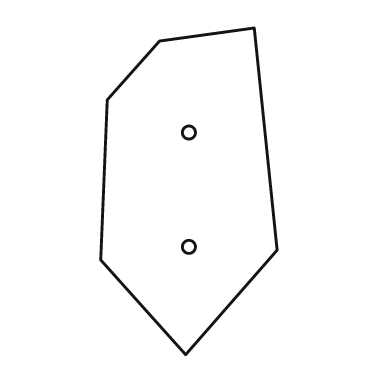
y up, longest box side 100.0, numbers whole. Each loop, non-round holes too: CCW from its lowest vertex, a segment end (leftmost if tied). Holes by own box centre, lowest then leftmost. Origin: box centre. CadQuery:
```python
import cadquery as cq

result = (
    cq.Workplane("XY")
    .moveTo(-1.0, -50.0)
    .lineTo(27.0, -18.0)
    .lineTo(20.0, 50.0)
    .lineTo(-9.0, 46.0)
    .lineTo(-25.0, 28.0)
    .lineTo(-27.0, -21.0)
    .close()
    .moveTo(0.0, -17.0)
    .circle(2.0)
    .moveTo(0.0, 18.0)
    .circle(2.0)
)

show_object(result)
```